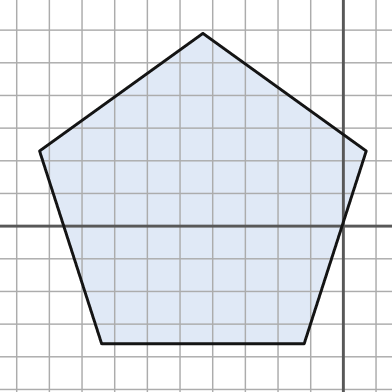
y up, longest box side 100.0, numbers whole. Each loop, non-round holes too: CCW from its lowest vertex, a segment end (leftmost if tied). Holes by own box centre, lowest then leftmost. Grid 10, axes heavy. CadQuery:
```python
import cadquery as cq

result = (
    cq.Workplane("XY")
    .moveTo(-74.0, -36.0)
    .lineTo(-12.0, -36.0)
    .lineTo(7.0, 23.0)
    .lineTo(-43.0, 59.0)
    .lineTo(-93.0, 23.0)
    .close()
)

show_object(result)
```